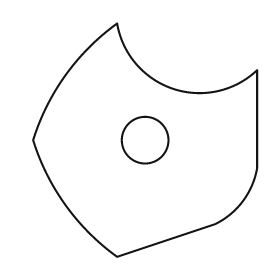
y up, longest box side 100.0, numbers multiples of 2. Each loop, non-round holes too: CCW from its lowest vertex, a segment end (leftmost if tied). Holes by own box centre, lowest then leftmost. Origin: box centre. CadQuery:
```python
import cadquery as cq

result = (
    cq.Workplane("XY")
    .moveTo(-12.0, -50.0)
    .lineTo(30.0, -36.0)
    .threePointArc((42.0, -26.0), (48.0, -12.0))
    .lineTo(48.0, 30.0)
    .threePointArc((12.0, 22.0), (-12.0, 50.0))
    .threePointArc((-34.0, 28.0), (-48.0, 0.0))
    .threePointArc((-34.0, -28.0), (-12.0, -50.0))
    .close()
    .moveTo(0.0, 0.0)
    .circle(10.0)
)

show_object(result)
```